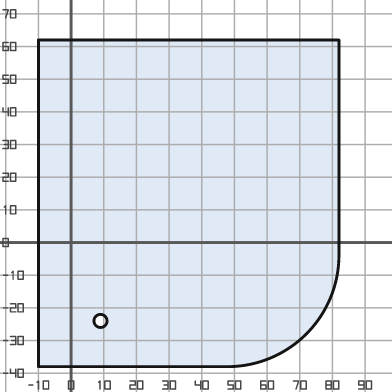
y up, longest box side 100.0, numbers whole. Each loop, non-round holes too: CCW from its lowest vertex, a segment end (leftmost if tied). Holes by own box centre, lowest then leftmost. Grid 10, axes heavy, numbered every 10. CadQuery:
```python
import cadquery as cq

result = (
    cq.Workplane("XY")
    .moveTo(-10.0, -38.0)
    .lineTo(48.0, -38.0)
    .threePointArc((72.0, -28.0), (82.0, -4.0))
    .lineTo(82.0, 62.0)
    .lineTo(-10.0, 62.0)
    .close()
    .moveTo(9.0, -24.0)
    .circle(2.0)
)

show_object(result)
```